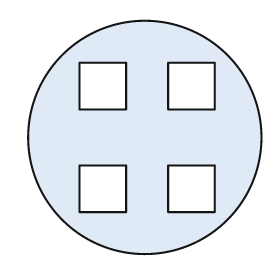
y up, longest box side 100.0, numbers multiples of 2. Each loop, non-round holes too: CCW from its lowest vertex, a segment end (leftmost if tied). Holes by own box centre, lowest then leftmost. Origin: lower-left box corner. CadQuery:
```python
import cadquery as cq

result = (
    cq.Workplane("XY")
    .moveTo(50.0, 50.0)
    .circle(50.0)
    .moveTo(22.0, 18.0)
    .lineTo(42.0, 18.0)
    .lineTo(42.0, 38.0)
    .lineTo(22.0, 38.0)
    .close()
    .moveTo(60.0, 18.0)
    .lineTo(80.0, 18.0)
    .lineTo(80.0, 38.0)
    .lineTo(60.0, 38.0)
    .close()
    .moveTo(22.0, 62.0)
    .lineTo(42.0, 62.0)
    .lineTo(42.0, 82.0)
    .lineTo(22.0, 82.0)
    .close()
    .moveTo(60.0, 62.0)
    .lineTo(80.0, 62.0)
    .lineTo(80.0, 82.0)
    .lineTo(60.0, 82.0)
    .close()
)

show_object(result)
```